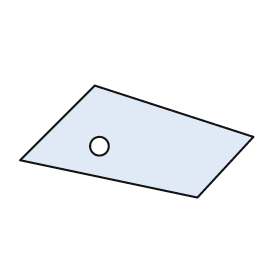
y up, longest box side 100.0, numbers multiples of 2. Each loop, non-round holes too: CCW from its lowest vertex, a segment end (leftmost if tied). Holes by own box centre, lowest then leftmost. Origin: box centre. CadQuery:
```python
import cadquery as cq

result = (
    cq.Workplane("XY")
    .moveTo(26.0, -24.0)
    .lineTo(50.0, 2.0)
    .lineTo(-18.0, 24.0)
    .lineTo(-50.0, -8.0)
    .close()
    .moveTo(-16.0, -2.0)
    .circle(4.0)
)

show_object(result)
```